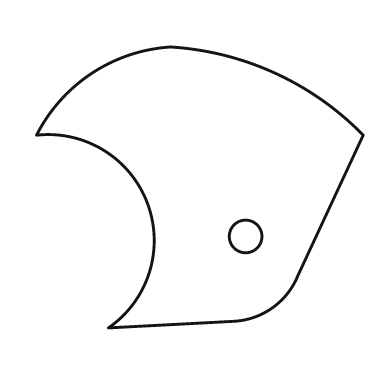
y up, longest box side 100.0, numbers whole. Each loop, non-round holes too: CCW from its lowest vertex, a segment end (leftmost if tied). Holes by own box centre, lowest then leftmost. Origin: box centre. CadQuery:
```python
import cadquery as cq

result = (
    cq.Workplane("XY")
    .moveTo(-28.0, -43.0)
    .lineTo(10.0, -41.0)
    .threePointArc((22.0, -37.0), (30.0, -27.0))
    .lineTo(50.0, 16.0)
    .threePointArc((23.0, 35.0), (-9.0, 43.0))
    .threePointArc((-33.0, 35.0), (-50.0, 16.0))
    .threePointArc((-16.0, -5.0), (-28.0, -43.0))
    .close()
    .moveTo(14.0, -15.0)
    .circle(5.0)
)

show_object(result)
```